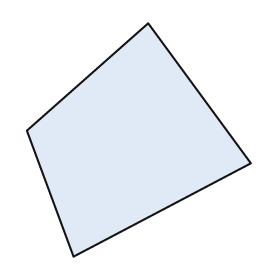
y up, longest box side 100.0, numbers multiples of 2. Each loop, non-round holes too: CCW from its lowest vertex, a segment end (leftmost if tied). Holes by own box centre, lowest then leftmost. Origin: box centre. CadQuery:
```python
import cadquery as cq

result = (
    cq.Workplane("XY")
    .moveTo(-28.0, -50.0)
    .lineTo(48.0, -10.0)
    .lineTo(4.0, 50.0)
    .lineTo(-48.0, 4.0)
    .close()
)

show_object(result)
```